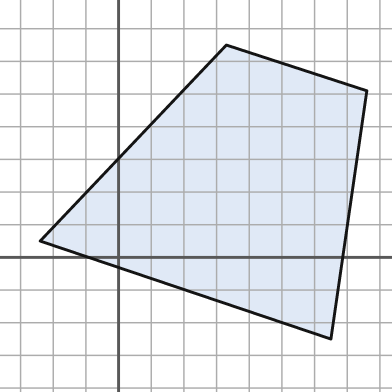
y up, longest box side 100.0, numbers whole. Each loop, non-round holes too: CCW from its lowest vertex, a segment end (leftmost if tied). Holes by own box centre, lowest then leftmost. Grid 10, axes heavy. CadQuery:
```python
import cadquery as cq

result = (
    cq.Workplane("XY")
    .moveTo(65.0, -25.0)
    .lineTo(76.0, 51.0)
    .lineTo(33.0, 65.0)
    .lineTo(-24.0, 5.0)
    .close()
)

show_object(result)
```